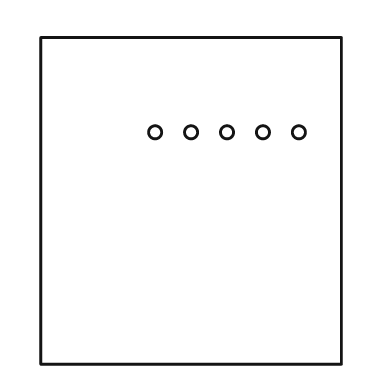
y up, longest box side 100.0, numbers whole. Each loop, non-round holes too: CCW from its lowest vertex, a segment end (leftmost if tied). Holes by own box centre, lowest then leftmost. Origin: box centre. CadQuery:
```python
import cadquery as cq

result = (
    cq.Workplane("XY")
    .moveTo(-46.0, -50.0)
    .lineTo(46.0, -50.0)
    .lineTo(46.0, 50.0)
    .lineTo(-46.0, 50.0)
    .close()
    .moveTo(-11.0, 21.0)
    .circle(2.0)
    .moveTo(0.0, 21.0)
    .circle(2.0)
    .moveTo(11.0, 21.0)
    .circle(2.0)
    .moveTo(22.0, 21.0)
    .circle(2.0)
    .moveTo(33.0, 21.0)
    .circle(2.0)
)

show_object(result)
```